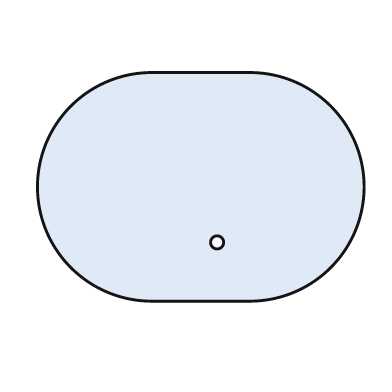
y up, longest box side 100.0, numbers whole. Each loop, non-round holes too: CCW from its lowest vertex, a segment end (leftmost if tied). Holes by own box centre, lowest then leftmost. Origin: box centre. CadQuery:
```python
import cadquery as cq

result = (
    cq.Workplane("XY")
    .moveTo(-15.0, -35.0)
    .lineTo(15.0, -35.0)
    .threePointArc((50.0, 0.0), (15.0, 35.0))
    .lineTo(-15.0, 35.0)
    .threePointArc((-50.0, 0.0), (-15.0, -35.0))
    .close()
    .moveTo(5.0, -17.0)
    .circle(2.0)
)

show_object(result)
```